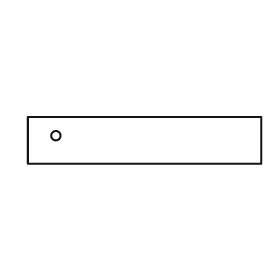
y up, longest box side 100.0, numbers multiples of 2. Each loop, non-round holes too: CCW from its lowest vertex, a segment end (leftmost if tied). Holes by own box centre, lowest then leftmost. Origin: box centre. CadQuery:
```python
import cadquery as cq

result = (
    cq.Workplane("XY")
    .moveTo(-50.0, -10.0)
    .lineTo(50.0, -10.0)
    .lineTo(50.0, 10.0)
    .lineTo(-50.0, 10.0)
    .close()
    .moveTo(-38.0, 2.0)
    .circle(2.0)
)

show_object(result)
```